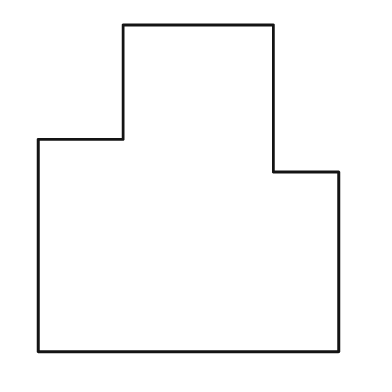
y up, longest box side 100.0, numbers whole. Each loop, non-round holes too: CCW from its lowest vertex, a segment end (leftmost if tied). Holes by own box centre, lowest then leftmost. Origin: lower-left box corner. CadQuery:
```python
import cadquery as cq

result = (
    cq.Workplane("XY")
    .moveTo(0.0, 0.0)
    .lineTo(92.0, 0.0)
    .lineTo(92.0, 55.0)
    .lineTo(72.0, 55.0)
    .lineTo(72.0, 100.0)
    .lineTo(26.0, 100.0)
    .lineTo(26.0, 65.0)
    .lineTo(0.0, 65.0)
    .close()
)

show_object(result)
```